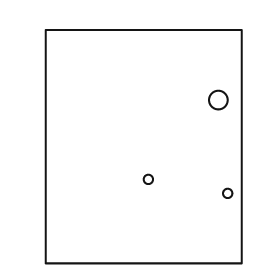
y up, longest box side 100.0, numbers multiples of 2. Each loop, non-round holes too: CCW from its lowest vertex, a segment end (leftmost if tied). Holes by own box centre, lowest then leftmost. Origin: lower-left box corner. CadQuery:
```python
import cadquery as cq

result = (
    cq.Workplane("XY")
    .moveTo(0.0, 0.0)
    .lineTo(84.0, 0.0)
    .lineTo(84.0, 100.0)
    .lineTo(0.0, 100.0)
    .close()
    .moveTo(78.0, 30.0)
    .circle(2.0)
    .moveTo(44.0, 36.0)
    .circle(2.0)
    .moveTo(74.0, 70.0)
    .circle(4.0)
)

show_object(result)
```